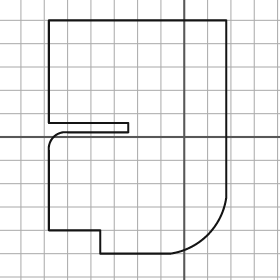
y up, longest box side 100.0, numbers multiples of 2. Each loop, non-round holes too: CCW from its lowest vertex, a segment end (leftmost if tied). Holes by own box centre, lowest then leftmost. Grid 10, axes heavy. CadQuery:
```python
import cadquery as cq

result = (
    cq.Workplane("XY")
    .moveTo(-36.0, -50.0)
    .lineTo(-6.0, -50.0)
    .threePointArc((10.0, -42.0), (18.0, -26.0))
    .lineTo(18.0, 50.0)
    .lineTo(-58.0, 50.0)
    .lineTo(-58.0, 6.0)
    .lineTo(-24.0, 6.0)
    .lineTo(-24.0, 2.0)
    .lineTo(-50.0, 2.0)
    .threePointArc((-56.0, 0.0), (-58.0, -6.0))
    .lineTo(-58.0, -40.0)
    .lineTo(-36.0, -40.0)
    .close()
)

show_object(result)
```